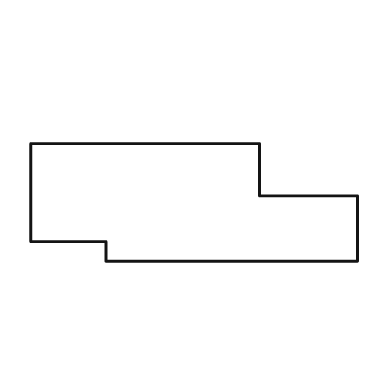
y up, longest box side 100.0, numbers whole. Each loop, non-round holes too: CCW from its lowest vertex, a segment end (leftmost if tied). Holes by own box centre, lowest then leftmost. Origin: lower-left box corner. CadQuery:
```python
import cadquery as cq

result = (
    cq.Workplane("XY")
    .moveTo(23.0, 0.0)
    .lineTo(100.0, 0.0)
    .lineTo(100.0, 20.0)
    .lineTo(70.0, 20.0)
    .lineTo(70.0, 36.0)
    .lineTo(0.0, 36.0)
    .lineTo(0.0, 6.0)
    .lineTo(23.0, 6.0)
    .close()
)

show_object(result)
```